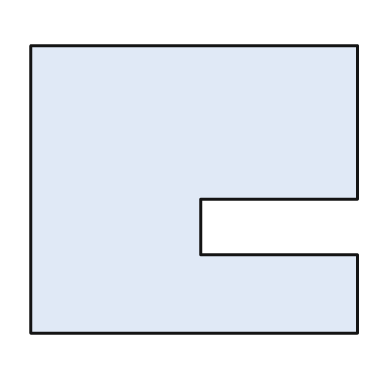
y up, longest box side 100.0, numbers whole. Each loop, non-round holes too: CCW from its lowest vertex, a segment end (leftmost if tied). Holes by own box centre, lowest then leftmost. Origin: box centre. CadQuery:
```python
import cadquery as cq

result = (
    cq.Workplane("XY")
    .moveTo(-50.0, -44.0)
    .lineTo(50.0, -44.0)
    .lineTo(50.0, -20.0)
    .lineTo(2.0, -20.0)
    .lineTo(2.0, -3.0)
    .lineTo(50.0, -3.0)
    .lineTo(50.0, 44.0)
    .lineTo(-50.0, 44.0)
    .close()
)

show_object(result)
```